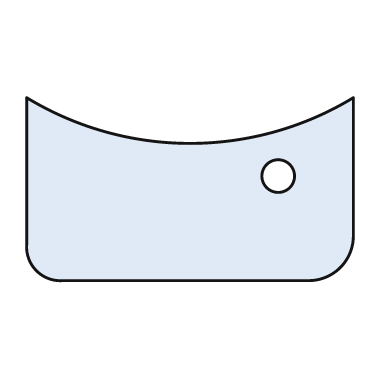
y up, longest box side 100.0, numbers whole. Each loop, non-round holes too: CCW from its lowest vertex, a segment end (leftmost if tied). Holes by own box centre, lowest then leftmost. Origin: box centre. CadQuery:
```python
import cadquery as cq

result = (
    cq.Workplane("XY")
    .moveTo(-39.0, -28.0)
    .lineTo(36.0, -28.0)
    .threePointArc((46.0, -24.0), (50.0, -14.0))
    .lineTo(50.0, 28.0)
    .threePointArc((0.0, 14.0), (-50.0, 28.0))
    .lineTo(-50.0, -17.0)
    .threePointArc((-47.0, -25.0), (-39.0, -28.0))
    .close()
    .moveTo(27.0, 4.0)
    .circle(5.0)
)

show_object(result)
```